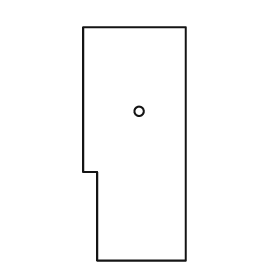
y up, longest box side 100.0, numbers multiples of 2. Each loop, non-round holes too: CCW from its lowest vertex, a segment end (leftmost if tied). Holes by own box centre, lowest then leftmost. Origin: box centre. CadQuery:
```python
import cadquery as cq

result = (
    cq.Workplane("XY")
    .moveTo(-16.0, -50.0)
    .lineTo(22.0, -50.0)
    .lineTo(22.0, 50.0)
    .lineTo(-22.0, 50.0)
    .lineTo(-22.0, -12.0)
    .lineTo(-16.0, -12.0)
    .close()
    .moveTo(2.0, 14.0)
    .circle(2.0)
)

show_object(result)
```